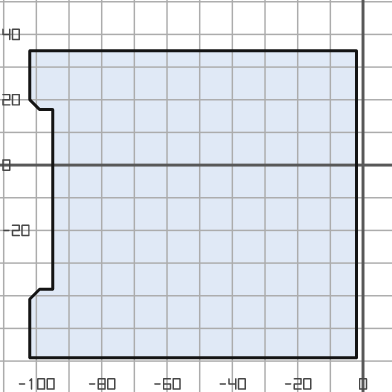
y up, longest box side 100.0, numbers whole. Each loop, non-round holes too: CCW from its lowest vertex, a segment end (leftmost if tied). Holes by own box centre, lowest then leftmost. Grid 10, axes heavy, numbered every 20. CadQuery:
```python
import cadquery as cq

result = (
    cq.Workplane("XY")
    .moveTo(-102.0, -59.0)
    .lineTo(-2.0, -59.0)
    .lineTo(-2.0, 35.0)
    .lineTo(-102.0, 35.0)
    .lineTo(-102.0, 20.0)
    .lineTo(-99.0, 17.0)
    .lineTo(-95.0, 17.0)
    .lineTo(-95.0, -38.0)
    .lineTo(-99.0, -38.0)
    .lineTo(-102.0, -41.0)
    .close()
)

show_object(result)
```